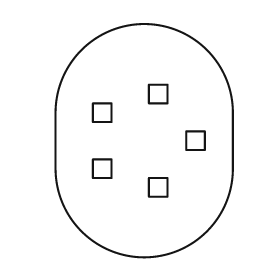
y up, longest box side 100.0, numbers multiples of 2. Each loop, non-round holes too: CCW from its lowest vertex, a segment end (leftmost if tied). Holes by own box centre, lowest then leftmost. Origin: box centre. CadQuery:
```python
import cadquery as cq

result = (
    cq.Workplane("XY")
    .moveTo(-38.0, -12.0)
    .threePointArc((0.0, -50.0), (38.0, -12.0))
    .lineTo(38.0, 12.0)
    .threePointArc((0.0, 50.0), (-38.0, 12.0))
    .close()
    .moveTo(2.0, -24.0)
    .lineTo(10.0, -24.0)
    .lineTo(10.0, -16.0)
    .lineTo(2.0, -16.0)
    .close()
    .moveTo(-22.0, -16.0)
    .lineTo(-14.0, -16.0)
    .lineTo(-14.0, -8.0)
    .lineTo(-22.0, -8.0)
    .close()
    .moveTo(18.0, -4.0)
    .lineTo(26.0, -4.0)
    .lineTo(26.0, 4.0)
    .lineTo(18.0, 4.0)
    .close()
    .moveTo(-22.0, 8.0)
    .lineTo(-14.0, 8.0)
    .lineTo(-14.0, 16.0)
    .lineTo(-22.0, 16.0)
    .close()
    .moveTo(2.0, 16.0)
    .lineTo(10.0, 16.0)
    .lineTo(10.0, 24.0)
    .lineTo(2.0, 24.0)
    .close()
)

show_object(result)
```